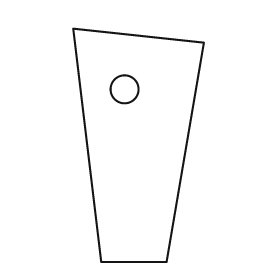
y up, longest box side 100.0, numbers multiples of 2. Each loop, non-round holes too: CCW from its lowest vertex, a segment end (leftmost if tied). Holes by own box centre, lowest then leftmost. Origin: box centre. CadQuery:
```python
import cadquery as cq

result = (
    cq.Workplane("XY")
    .moveTo(-16.0, -50.0)
    .lineTo(12.0, -50.0)
    .lineTo(28.0, 44.0)
    .lineTo(-28.0, 50.0)
    .close()
    .moveTo(-6.0, 24.0)
    .circle(6.0)
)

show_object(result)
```